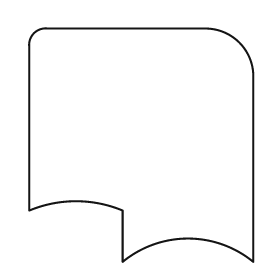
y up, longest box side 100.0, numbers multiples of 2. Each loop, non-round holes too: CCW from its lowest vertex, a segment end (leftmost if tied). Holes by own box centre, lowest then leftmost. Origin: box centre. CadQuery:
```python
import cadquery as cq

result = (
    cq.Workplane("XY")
    .moveTo(-8.0, -50.0)
    .threePointArc((20.0, -40.0), (48.0, -50.0))
    .lineTo(48.0, 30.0)
    .threePointArc((42.0, 44.0), (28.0, 50.0))
    .lineTo(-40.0, 50.0)
    .threePointArc((-46.0, 48.0), (-48.0, 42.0))
    .lineTo(-48.0, -28.0)
    .threePointArc((-28.0, -24.0), (-8.0, -28.0))
    .close()
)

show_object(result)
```